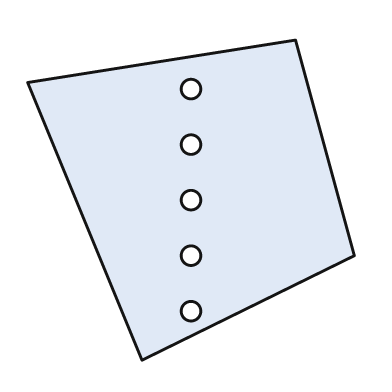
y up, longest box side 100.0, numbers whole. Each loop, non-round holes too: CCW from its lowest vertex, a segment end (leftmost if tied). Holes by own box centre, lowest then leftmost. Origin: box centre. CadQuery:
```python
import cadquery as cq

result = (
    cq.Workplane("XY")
    .moveTo(-15.0, -49.0)
    .lineTo(50.0, -17.0)
    .lineTo(32.0, 49.0)
    .lineTo(-50.0, 36.0)
    .close()
    .moveTo(0.0, -34.0)
    .circle(3.0)
    .moveTo(0.0, -17.0)
    .circle(3.0)
    .moveTo(0.0, 0.0)
    .circle(3.0)
    .moveTo(0.0, 17.0)
    .circle(3.0)
    .moveTo(0.0, 34.0)
    .circle(3.0)
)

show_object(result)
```